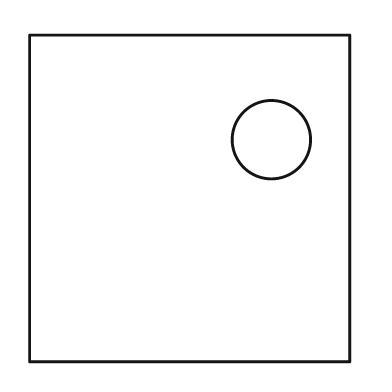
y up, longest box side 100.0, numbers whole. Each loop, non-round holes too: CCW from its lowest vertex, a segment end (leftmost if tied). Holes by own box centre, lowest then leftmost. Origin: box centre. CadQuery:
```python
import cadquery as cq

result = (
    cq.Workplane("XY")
    .moveTo(-49.0, -50.0)
    .lineTo(49.0, -50.0)
    .lineTo(49.0, 50.0)
    .lineTo(-49.0, 50.0)
    .close()
    .moveTo(25.0, 18.0)
    .circle(12.0)
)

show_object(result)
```